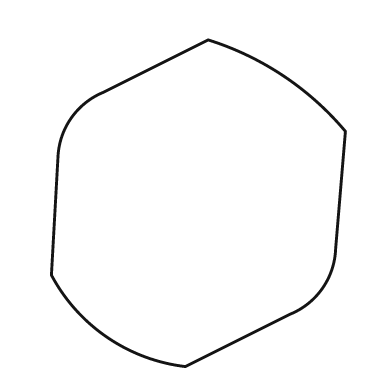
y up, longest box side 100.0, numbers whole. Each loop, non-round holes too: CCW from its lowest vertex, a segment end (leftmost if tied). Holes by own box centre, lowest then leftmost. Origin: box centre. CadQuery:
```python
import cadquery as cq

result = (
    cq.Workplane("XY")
    .moveTo(-4.0, -50.0)
    .lineTo(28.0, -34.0)
    .threePointArc((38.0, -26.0), (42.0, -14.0))
    .lineTo(45.0, 22.0)
    .threePointArc((26.0, 39.0), (3.0, 50.0))
    .lineTo(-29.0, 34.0)
    .threePointArc((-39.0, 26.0), (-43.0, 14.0))
    .lineTo(-45.0, -22.0)
    .threePointArc((-28.0, -41.0), (-4.0, -50.0))
    .close()
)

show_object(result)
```